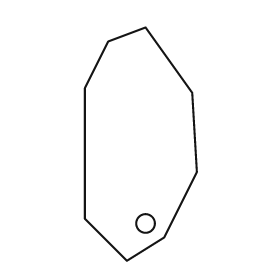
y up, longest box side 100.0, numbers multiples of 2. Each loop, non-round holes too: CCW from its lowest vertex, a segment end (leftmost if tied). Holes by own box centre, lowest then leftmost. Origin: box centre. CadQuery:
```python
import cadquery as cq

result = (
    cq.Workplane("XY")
    .moveTo(-6.0, -50.0)
    .lineTo(10.0, -40.0)
    .lineTo(24.0, -12.0)
    .lineTo(22.0, 22.0)
    .lineTo(2.0, 50.0)
    .lineTo(-14.0, 44.0)
    .lineTo(-24.0, 24.0)
    .lineTo(-24.0, -32.0)
    .close()
    .moveTo(2.0, -34.0)
    .circle(4.0)
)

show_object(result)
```